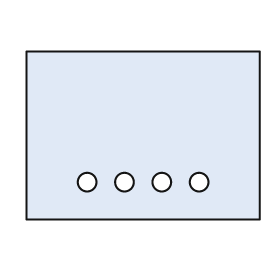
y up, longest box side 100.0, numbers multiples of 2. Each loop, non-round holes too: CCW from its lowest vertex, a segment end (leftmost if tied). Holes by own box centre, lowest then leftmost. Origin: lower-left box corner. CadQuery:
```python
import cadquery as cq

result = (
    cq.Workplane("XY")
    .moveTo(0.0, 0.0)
    .lineTo(100.0, 0.0)
    .lineTo(100.0, 72.0)
    .lineTo(0.0, 72.0)
    .close()
    .moveTo(26.0, 16.0)
    .circle(4.0)
    .moveTo(42.0, 16.0)
    .circle(4.0)
    .moveTo(58.0, 16.0)
    .circle(4.0)
    .moveTo(74.0, 16.0)
    .circle(4.0)
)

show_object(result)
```